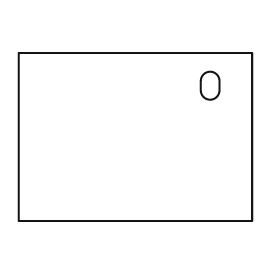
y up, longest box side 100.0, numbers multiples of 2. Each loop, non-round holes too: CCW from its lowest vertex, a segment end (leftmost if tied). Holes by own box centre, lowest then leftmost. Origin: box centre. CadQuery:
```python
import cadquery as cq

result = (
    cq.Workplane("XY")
    .moveTo(-50.0, -36.0)
    .lineTo(50.0, -36.0)
    .lineTo(50.0, 36.0)
    .lineTo(-50.0, 36.0)
    .close()
    .moveTo(28.0, 20.0)
    .threePointArc((32.0, 16.0), (36.0, 20.0))
    .lineTo(36.0, 24.0)
    .threePointArc((32.0, 28.0), (28.0, 24.0))
    .close()
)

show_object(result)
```